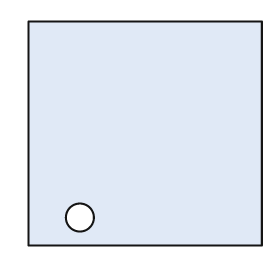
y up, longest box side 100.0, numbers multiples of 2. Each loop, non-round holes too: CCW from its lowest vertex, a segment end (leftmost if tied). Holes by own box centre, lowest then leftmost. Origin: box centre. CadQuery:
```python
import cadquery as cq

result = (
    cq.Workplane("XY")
    .moveTo(-50.0, -48.0)
    .lineTo(50.0, -48.0)
    .lineTo(50.0, 48.0)
    .lineTo(-50.0, 48.0)
    .close()
    .moveTo(-28.0, -36.0)
    .circle(6.0)
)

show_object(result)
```